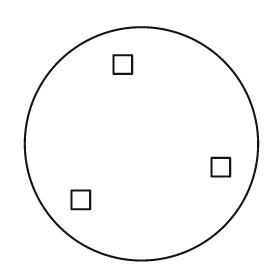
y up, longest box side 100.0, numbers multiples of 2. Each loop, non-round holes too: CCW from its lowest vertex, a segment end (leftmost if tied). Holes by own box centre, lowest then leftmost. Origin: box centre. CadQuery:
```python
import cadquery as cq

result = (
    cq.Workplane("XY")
    .moveTo(0.0, 0.0)
    .circle(50.0)
    .moveTo(-30.0, -28.0)
    .lineTo(-22.0, -28.0)
    .lineTo(-22.0, -20.0)
    .lineTo(-30.0, -20.0)
    .close()
    .moveTo(30.0, -14.0)
    .lineTo(38.0, -14.0)
    .lineTo(38.0, -6.0)
    .lineTo(30.0, -6.0)
    .close()
    .moveTo(-12.0, 30.0)
    .lineTo(-4.0, 30.0)
    .lineTo(-4.0, 38.0)
    .lineTo(-12.0, 38.0)
    .close()
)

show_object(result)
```